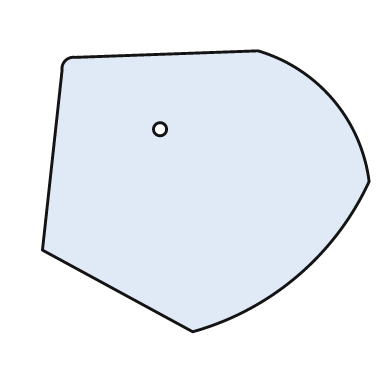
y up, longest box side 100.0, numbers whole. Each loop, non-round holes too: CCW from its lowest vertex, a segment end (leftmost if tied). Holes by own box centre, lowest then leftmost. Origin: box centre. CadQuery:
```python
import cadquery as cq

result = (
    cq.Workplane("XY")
    .moveTo(-4.0, -43.0)
    .threePointArc((28.0, -26.0), (50.0, 3.0))
    .threePointArc((39.0, 28.0), (16.0, 43.0))
    .lineTo(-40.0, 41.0)
    .threePointArc((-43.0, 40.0), (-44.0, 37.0))
    .lineTo(-50.0, -18.0)
    .close()
    .moveTo(-14.0, 19.0)
    .circle(2.0)
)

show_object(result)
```